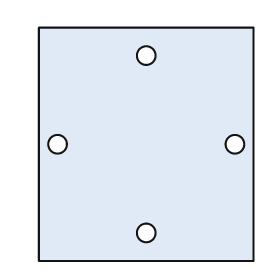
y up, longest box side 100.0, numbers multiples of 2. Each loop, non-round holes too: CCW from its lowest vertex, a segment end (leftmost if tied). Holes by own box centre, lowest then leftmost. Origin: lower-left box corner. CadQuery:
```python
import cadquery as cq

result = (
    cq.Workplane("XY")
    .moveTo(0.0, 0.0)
    .lineTo(92.0, 0.0)
    .lineTo(92.0, 100.0)
    .lineTo(0.0, 100.0)
    .close()
    .moveTo(46.0, 12.0)
    .circle(4.0)
    .moveTo(8.0, 50.0)
    .circle(4.0)
    .moveTo(84.0, 50.0)
    .circle(4.0)
    .moveTo(46.0, 88.0)
    .circle(4.0)
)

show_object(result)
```